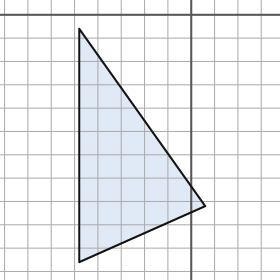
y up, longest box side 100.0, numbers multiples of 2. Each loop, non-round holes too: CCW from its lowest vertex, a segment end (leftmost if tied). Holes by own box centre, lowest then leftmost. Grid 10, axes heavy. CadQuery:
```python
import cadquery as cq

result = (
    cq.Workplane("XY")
    .moveTo(-48.0, -106.0)
    .lineTo(6.0, -82.0)
    .lineTo(-48.0, -6.0)
    .close()
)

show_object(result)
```